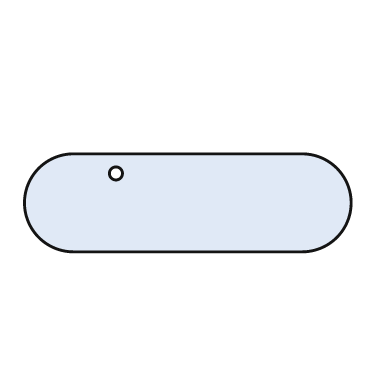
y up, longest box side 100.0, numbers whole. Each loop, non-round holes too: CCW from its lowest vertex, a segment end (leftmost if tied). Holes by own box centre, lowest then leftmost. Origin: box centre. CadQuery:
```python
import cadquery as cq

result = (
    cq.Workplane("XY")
    .moveTo(-35.0, -15.0)
    .lineTo(35.0, -15.0)
    .threePointArc((50.0, 0.0), (35.0, 15.0))
    .lineTo(-35.0, 15.0)
    .threePointArc((-50.0, 0.0), (-35.0, -15.0))
    .close()
    .moveTo(-22.0, 9.0)
    .circle(2.0)
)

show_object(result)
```